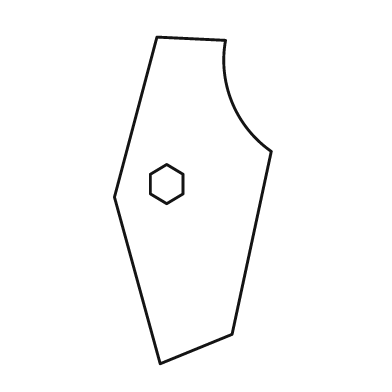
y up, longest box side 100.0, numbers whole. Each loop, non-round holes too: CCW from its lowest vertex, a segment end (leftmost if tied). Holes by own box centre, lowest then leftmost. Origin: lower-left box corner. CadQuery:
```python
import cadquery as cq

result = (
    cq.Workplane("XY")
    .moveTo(14.0, 0.0)
    .lineTo(36.0, 9.0)
    .lineTo(48.0, 65.0)
    .threePointArc((36.0, 80.0), (34.0, 99.0))
    .lineTo(13.0, 100.0)
    .lineTo(0.0, 51.0)
    .close()
    .moveTo(16.0, 49.0)
    .lineTo(21.0, 52.0)
    .lineTo(21.0, 58.0)
    .lineTo(16.0, 61.0)
    .lineTo(11.0, 58.0)
    .lineTo(11.0, 52.0)
    .close()
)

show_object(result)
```